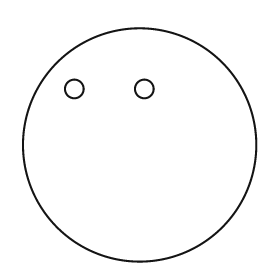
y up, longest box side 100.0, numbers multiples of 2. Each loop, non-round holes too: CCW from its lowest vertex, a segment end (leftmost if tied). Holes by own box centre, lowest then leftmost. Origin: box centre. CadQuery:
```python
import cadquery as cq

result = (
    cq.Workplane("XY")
    .moveTo(0.0, 0.0)
    .circle(50.0)
    .moveTo(-28.0, 24.0)
    .circle(4.0)
    .moveTo(2.0, 24.0)
    .circle(4.0)
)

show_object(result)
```